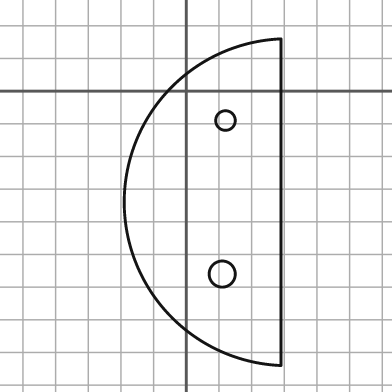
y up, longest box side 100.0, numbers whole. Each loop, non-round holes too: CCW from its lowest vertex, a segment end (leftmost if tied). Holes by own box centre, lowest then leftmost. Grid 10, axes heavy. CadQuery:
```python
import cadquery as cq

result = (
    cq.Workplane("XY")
    .moveTo(29.0, -84.0)
    .lineTo(29.0, 16.0)
    .threePointArc((-19.0, -34.0), (29.0, -84.0))
    .close()
    .moveTo(11.0, -56.0)
    .circle(4.0)
    .moveTo(12.0, -9.0)
    .circle(3.0)
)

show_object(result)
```